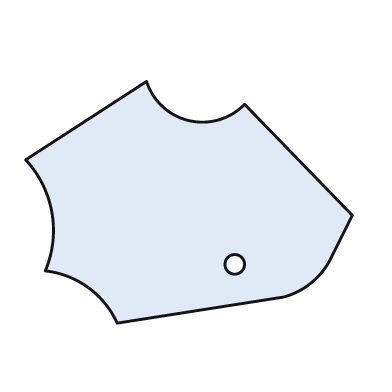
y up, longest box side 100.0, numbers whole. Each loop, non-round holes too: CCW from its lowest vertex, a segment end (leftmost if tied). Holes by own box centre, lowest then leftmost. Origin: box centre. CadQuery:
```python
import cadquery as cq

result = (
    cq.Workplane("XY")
    .moveTo(-22.0, -37.0)
    .lineTo(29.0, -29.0)
    .threePointArc((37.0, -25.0), (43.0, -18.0))
    .lineTo(50.0, -4.0)
    .lineTo(17.0, 30.0)
    .threePointArc((0.0, 25.0), (-13.0, 37.0))
    .lineTo(-50.0, 13.0)
    .threePointArc((-42.0, -3.0), (-44.0, -21.0))
    .threePointArc((-31.0, -26.0), (-22.0, -37.0))
    .close()
    .moveTo(14.0, -19.0)
    .circle(3.0)
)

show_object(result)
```